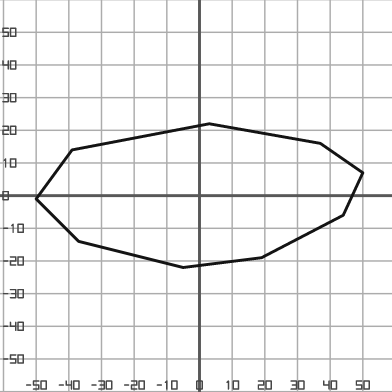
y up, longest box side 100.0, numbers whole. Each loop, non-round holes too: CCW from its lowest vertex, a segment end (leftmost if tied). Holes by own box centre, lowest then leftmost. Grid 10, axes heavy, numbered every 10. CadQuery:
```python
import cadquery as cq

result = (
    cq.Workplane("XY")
    .moveTo(-5.0, -22.0)
    .lineTo(19.0, -19.0)
    .lineTo(44.0, -6.0)
    .lineTo(50.0, 7.0)
    .lineTo(37.0, 16.0)
    .lineTo(3.0, 22.0)
    .lineTo(-39.0, 14.0)
    .lineTo(-50.0, -1.0)
    .lineTo(-37.0, -14.0)
    .close()
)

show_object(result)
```